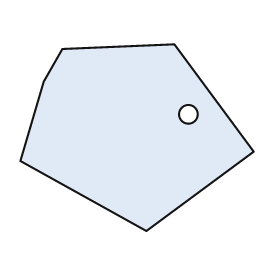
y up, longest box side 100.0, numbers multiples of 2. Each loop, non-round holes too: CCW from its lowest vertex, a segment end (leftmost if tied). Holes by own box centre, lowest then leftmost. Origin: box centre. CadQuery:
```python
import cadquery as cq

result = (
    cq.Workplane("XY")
    .moveTo(4.0, -40.0)
    .lineTo(50.0, -6.0)
    .lineTo(16.0, 40.0)
    .lineTo(-32.0, 38.0)
    .lineTo(-40.0, 24.0)
    .lineTo(-50.0, -10.0)
    .close()
    .moveTo(22.0, 10.0)
    .circle(4.0)
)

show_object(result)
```